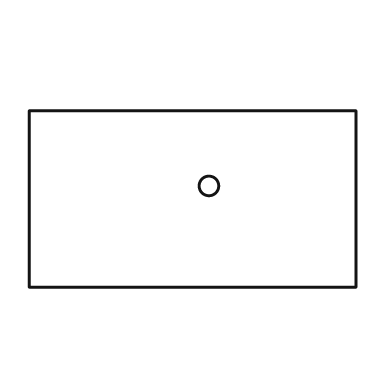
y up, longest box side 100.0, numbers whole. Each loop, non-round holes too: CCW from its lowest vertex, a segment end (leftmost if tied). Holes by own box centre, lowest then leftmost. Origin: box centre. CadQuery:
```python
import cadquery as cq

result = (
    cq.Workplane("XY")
    .moveTo(-50.0, -27.0)
    .lineTo(50.0, -27.0)
    .lineTo(50.0, 27.0)
    .lineTo(-50.0, 27.0)
    .close()
    .moveTo(5.0, 4.0)
    .circle(3.0)
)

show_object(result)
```